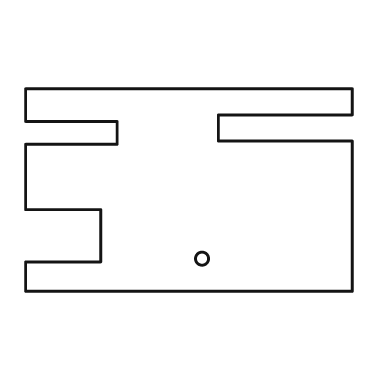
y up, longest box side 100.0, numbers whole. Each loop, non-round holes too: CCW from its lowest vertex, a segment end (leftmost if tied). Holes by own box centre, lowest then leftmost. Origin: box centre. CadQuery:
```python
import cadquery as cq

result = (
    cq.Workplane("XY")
    .moveTo(-50.0, -31.0)
    .lineTo(50.0, -31.0)
    .lineTo(50.0, 15.0)
    .lineTo(9.0, 15.0)
    .lineTo(9.0, 23.0)
    .lineTo(50.0, 23.0)
    .lineTo(50.0, 31.0)
    .lineTo(-50.0, 31.0)
    .lineTo(-50.0, 21.0)
    .lineTo(-22.0, 21.0)
    .lineTo(-22.0, 14.0)
    .lineTo(-50.0, 14.0)
    .lineTo(-50.0, -6.0)
    .lineTo(-27.0, -6.0)
    .lineTo(-27.0, -22.0)
    .lineTo(-50.0, -22.0)
    .close()
    .moveTo(4.0, -21.0)
    .circle(2.0)
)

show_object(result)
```